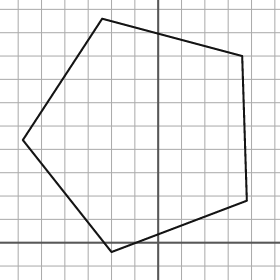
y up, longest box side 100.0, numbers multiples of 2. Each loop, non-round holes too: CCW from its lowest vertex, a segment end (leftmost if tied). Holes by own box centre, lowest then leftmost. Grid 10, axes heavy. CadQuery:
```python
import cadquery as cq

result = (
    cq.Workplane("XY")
    .moveTo(-20.0, -4.0)
    .lineTo(38.0, 18.0)
    .lineTo(36.0, 80.0)
    .lineTo(-24.0, 96.0)
    .lineTo(-58.0, 44.0)
    .close()
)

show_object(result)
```